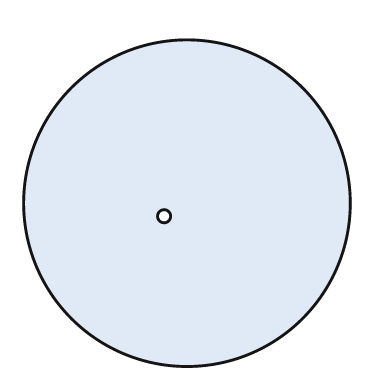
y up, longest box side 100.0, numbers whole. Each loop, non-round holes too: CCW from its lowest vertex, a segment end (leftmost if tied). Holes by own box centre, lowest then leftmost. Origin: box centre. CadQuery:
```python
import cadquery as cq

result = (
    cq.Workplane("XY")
    .moveTo(0.0, 0.0)
    .circle(50.0)
    .moveTo(-7.0, -4.0)
    .circle(2.0)
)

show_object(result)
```